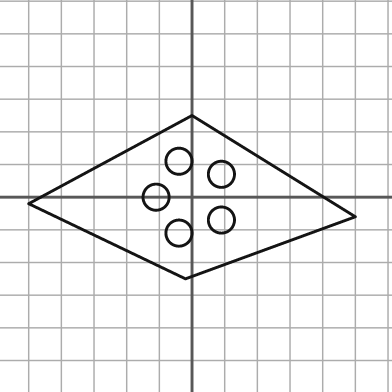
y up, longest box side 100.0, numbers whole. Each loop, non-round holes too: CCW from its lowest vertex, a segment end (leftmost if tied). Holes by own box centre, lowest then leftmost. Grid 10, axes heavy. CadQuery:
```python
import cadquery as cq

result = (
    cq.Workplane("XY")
    .moveTo(-2.0, -25.0)
    .lineTo(50.0, -6.0)
    .lineTo(0.0, 25.0)
    .lineTo(-50.0, -2.0)
    .close()
    .moveTo(-4.0, -11.0)
    .circle(4.0)
    .moveTo(9.0, -7.0)
    .circle(4.0)
    .moveTo(-11.0, 0.0)
    .circle(4.0)
    .moveTo(9.0, 7.0)
    .circle(4.0)
    .moveTo(-4.0, 11.0)
    .circle(4.0)
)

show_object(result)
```